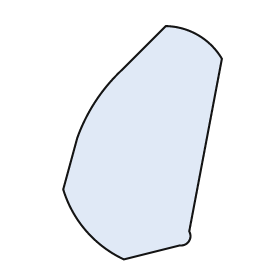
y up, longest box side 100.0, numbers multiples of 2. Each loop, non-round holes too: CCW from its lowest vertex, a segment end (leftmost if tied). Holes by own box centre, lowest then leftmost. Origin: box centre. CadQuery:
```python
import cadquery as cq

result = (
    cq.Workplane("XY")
    .moveTo(-8.0, -50.0)
    .lineTo(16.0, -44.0)
    .threePointArc((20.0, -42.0), (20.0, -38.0))
    .lineTo(34.0, 36.0)
    .threePointArc((24.0, 46.0), (10.0, 50.0))
    .lineTo(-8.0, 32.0)
    .threePointArc((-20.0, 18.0), (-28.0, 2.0))
    .lineTo(-34.0, -20.0)
    .threePointArc((-24.0, -38.0), (-8.0, -50.0))
    .close()
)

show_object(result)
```